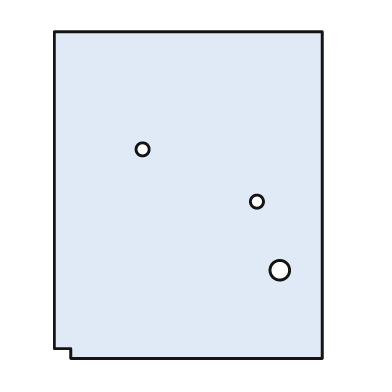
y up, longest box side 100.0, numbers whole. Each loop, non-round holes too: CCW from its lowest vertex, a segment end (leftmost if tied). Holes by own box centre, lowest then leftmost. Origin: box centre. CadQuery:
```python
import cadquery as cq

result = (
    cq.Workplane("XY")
    .moveTo(-36.0, -50.0)
    .lineTo(41.0, -50.0)
    .lineTo(41.0, 50.0)
    .lineTo(-41.0, 50.0)
    .lineTo(-41.0, -47.0)
    .lineTo(-36.0, -47.0)
    .close()
    .moveTo(28.0, -23.0)
    .circle(3.0)
    .moveTo(21.0, -2.0)
    .circle(2.0)
    .moveTo(-14.0, 14.0)
    .circle(2.0)
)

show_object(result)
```